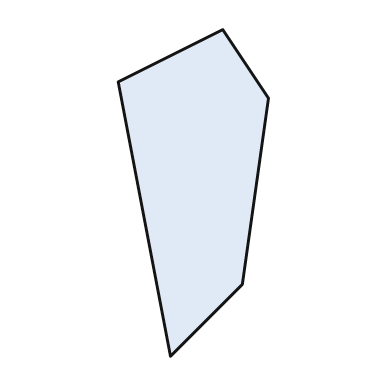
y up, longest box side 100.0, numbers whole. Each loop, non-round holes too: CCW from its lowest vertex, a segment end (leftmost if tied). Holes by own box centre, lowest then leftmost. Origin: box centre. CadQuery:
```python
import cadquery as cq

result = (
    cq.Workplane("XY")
    .moveTo(-7.0, -50.0)
    .lineTo(15.0, -28.0)
    .lineTo(23.0, 29.0)
    .lineTo(9.0, 50.0)
    .lineTo(-23.0, 34.0)
    .close()
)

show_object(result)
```